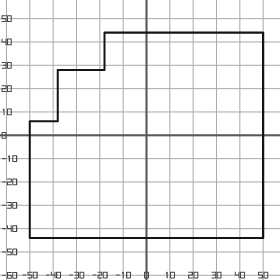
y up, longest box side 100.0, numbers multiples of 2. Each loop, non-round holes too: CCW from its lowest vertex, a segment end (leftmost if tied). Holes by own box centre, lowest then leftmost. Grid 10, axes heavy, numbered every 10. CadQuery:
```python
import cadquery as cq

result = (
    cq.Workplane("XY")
    .moveTo(-50.0, -44.0)
    .lineTo(50.0, -44.0)
    .lineTo(50.0, 44.0)
    .lineTo(-18.0, 44.0)
    .lineTo(-18.0, 28.0)
    .lineTo(-38.0, 28.0)
    .lineTo(-38.0, 6.0)
    .lineTo(-50.0, 6.0)
    .close()
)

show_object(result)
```